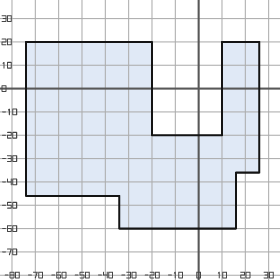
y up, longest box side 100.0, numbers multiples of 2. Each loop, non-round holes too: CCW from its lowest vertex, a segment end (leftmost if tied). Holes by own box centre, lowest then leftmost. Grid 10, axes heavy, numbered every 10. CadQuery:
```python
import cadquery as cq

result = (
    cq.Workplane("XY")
    .moveTo(-34.0, -60.0)
    .lineTo(16.0, -60.0)
    .lineTo(16.0, -36.0)
    .lineTo(26.0, -36.0)
    .lineTo(26.0, 20.0)
    .lineTo(10.0, 20.0)
    .lineTo(10.0, -20.0)
    .lineTo(-20.0, -20.0)
    .lineTo(-20.0, 20.0)
    .lineTo(-74.0, 20.0)
    .lineTo(-74.0, -46.0)
    .lineTo(-34.0, -46.0)
    .close()
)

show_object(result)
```